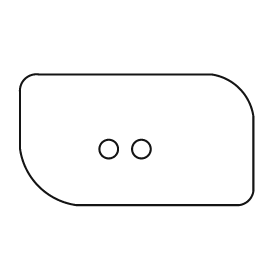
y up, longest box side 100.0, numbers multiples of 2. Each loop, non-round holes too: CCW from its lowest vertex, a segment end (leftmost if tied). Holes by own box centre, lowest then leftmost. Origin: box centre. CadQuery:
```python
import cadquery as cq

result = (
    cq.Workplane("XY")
    .moveTo(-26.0, -28.0)
    .lineTo(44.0, -28.0)
    .threePointArc((48.0, -26.0), (50.0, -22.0))
    .lineTo(50.0, 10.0)
    .threePointArc((44.0, 22.0), (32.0, 28.0))
    .lineTo(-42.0, 28.0)
    .threePointArc((-48.0, 26.0), (-50.0, 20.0))
    .lineTo(-50.0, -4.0)
    .threePointArc((-42.0, -20.0), (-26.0, -28.0))
    .close()
    .moveTo(-12.0, -4.0)
    .circle(4.0)
    .moveTo(2.0, -4.0)
    .circle(4.0)
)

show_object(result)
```